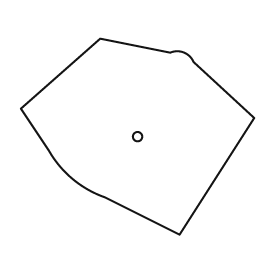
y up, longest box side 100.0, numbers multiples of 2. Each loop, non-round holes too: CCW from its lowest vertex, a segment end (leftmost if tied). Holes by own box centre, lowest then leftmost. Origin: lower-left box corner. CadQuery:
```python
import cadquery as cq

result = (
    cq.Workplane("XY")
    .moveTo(68.0, 0.0)
    .lineTo(100.0, 50.0)
    .lineTo(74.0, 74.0)
    .threePointArc((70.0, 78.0), (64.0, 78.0))
    .lineTo(34.0, 84.0)
    .lineTo(0.0, 54.0)
    .lineTo(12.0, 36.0)
    .threePointArc((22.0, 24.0), (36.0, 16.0))
    .close()
    .moveTo(50.0, 42.0)
    .circle(2.0)
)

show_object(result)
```